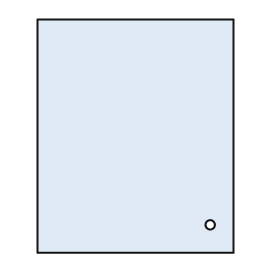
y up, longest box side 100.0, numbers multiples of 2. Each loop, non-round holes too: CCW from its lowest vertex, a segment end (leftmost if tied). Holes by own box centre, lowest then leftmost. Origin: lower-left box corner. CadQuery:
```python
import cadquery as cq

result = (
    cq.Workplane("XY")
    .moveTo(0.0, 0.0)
    .lineTo(84.0, 0.0)
    .lineTo(84.0, 100.0)
    .lineTo(0.0, 100.0)
    .close()
    .moveTo(74.0, 12.0)
    .circle(2.0)
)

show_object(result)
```